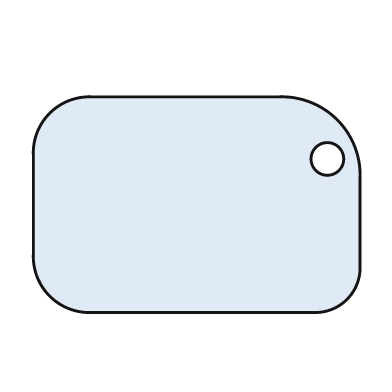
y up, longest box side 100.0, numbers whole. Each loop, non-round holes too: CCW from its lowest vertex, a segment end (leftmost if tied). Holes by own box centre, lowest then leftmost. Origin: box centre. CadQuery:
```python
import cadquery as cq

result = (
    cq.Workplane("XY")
    .moveTo(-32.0, -33.0)
    .lineTo(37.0, -33.0)
    .threePointArc((46.0, -29.0), (50.0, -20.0))
    .lineTo(50.0, 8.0)
    .threePointArc((43.0, 26.0), (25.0, 33.0))
    .lineTo(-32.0, 33.0)
    .threePointArc((-45.0, 28.0), (-50.0, 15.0))
    .lineTo(-50.0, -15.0)
    .threePointArc((-45.0, -28.0), (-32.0, -33.0))
    .close()
    .moveTo(40.0, 14.0)
    .circle(5.0)
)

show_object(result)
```